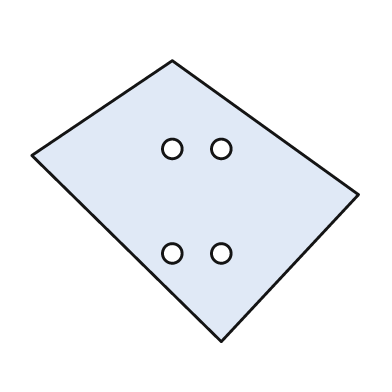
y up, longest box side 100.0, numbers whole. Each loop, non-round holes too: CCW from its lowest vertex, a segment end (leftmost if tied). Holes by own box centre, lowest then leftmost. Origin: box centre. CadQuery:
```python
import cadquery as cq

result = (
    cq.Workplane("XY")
    .moveTo(8.0, -43.0)
    .lineTo(50.0, 2.0)
    .lineTo(-7.0, 43.0)
    .lineTo(-50.0, 14.0)
    .close()
    .moveTo(-7.0, -16.0)
    .circle(3.0)
    .moveTo(8.0, -16.0)
    .circle(3.0)
    .moveTo(-7.0, 16.0)
    .circle(3.0)
    .moveTo(8.0, 16.0)
    .circle(3.0)
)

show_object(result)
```